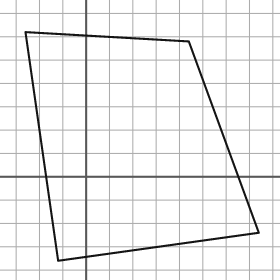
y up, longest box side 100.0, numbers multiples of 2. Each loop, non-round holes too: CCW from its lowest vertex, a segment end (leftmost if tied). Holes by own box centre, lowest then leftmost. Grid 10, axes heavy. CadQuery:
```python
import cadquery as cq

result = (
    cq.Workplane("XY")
    .moveTo(-12.0, -36.0)
    .lineTo(74.0, -24.0)
    .lineTo(44.0, 58.0)
    .lineTo(-26.0, 62.0)
    .close()
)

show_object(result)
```